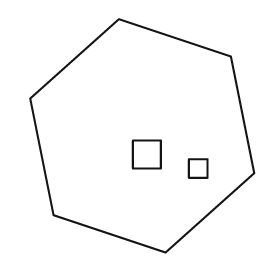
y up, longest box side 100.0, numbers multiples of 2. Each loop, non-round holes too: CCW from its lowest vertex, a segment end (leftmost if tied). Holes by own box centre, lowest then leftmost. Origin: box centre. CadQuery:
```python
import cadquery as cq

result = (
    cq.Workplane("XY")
    .moveTo(10.0, -50.0)
    .lineTo(48.0, -16.0)
    .lineTo(38.0, 34.0)
    .lineTo(-10.0, 50.0)
    .lineTo(-48.0, 16.0)
    .lineTo(-38.0, -34.0)
    .close()
    .moveTo(20.0, -18.0)
    .lineTo(28.0, -18.0)
    .lineTo(28.0, -10.0)
    .lineTo(20.0, -10.0)
    .close()
    .moveTo(-4.0, -14.0)
    .lineTo(8.0, -14.0)
    .lineTo(8.0, -2.0)
    .lineTo(-4.0, -2.0)
    .close()
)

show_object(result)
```